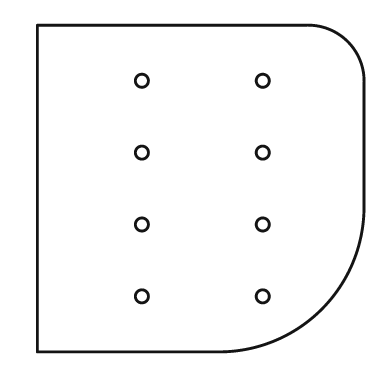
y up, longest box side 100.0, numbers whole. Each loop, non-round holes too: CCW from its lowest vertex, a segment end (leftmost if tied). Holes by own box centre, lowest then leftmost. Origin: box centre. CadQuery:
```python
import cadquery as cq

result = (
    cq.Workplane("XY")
    .moveTo(-50.0, -50.0)
    .lineTo(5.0, -50.0)
    .threePointArc((37.0, -37.0), (50.0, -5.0))
    .lineTo(50.0, 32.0)
    .threePointArc((45.0, 45.0), (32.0, 50.0))
    .lineTo(-50.0, 50.0)
    .close()
    .moveTo(-18.0, -33.0)
    .circle(2.0)
    .moveTo(19.0, -33.0)
    .circle(2.0)
    .moveTo(-18.0, -11.0)
    .circle(2.0)
    .moveTo(19.0, -11.0)
    .circle(2.0)
    .moveTo(-18.0, 11.0)
    .circle(2.0)
    .moveTo(19.0, 11.0)
    .circle(2.0)
    .moveTo(-18.0, 33.0)
    .circle(2.0)
    .moveTo(19.0, 33.0)
    .circle(2.0)
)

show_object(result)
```